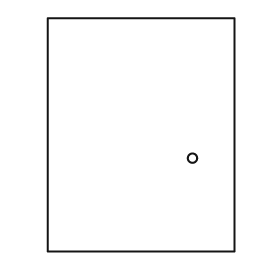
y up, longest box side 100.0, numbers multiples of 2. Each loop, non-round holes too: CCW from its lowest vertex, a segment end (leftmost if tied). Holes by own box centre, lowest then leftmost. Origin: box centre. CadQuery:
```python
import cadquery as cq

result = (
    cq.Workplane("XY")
    .moveTo(-40.0, -50.0)
    .lineTo(40.0, -50.0)
    .lineTo(40.0, 50.0)
    .lineTo(-40.0, 50.0)
    .close()
    .moveTo(22.0, -10.0)
    .circle(2.0)
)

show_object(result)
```